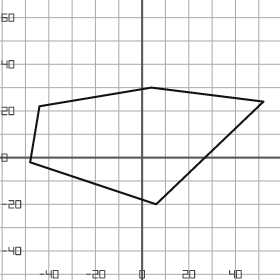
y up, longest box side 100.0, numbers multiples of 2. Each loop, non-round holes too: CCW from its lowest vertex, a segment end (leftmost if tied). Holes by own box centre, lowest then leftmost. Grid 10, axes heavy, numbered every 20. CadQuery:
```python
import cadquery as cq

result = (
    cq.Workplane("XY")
    .moveTo(6.0, -20.0)
    .lineTo(52.0, 24.0)
    .lineTo(4.0, 30.0)
    .lineTo(-44.0, 22.0)
    .lineTo(-48.0, -2.0)
    .close()
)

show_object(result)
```